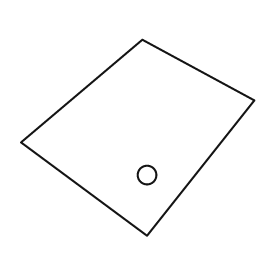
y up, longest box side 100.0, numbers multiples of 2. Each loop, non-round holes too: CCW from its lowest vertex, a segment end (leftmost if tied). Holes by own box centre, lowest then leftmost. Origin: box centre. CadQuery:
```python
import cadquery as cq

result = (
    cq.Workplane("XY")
    .moveTo(4.0, -42.0)
    .lineTo(50.0, 16.0)
    .lineTo(2.0, 42.0)
    .lineTo(-50.0, -2.0)
    .close()
    .moveTo(4.0, -16.0)
    .circle(4.0)
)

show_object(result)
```